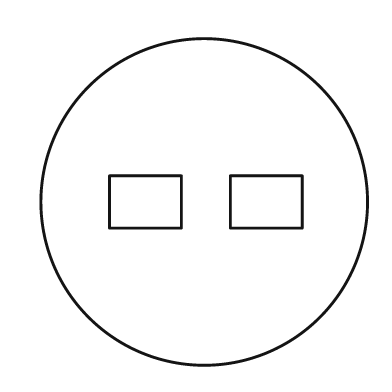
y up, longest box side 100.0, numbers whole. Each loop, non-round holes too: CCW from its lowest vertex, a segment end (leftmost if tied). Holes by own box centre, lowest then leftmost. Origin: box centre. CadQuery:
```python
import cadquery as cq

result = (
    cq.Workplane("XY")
    .moveTo(0.0, 0.0)
    .circle(50.0)
    .moveTo(-29.0, -8.0)
    .lineTo(-7.0, -8.0)
    .lineTo(-7.0, 8.0)
    .lineTo(-29.0, 8.0)
    .close()
    .moveTo(8.0, -8.0)
    .lineTo(30.0, -8.0)
    .lineTo(30.0, 8.0)
    .lineTo(8.0, 8.0)
    .close()
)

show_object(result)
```